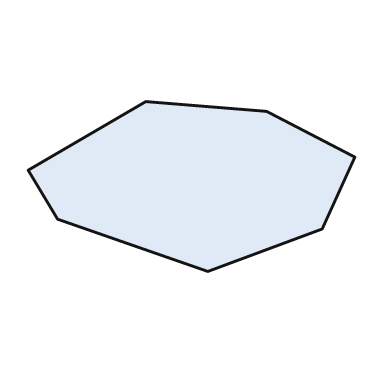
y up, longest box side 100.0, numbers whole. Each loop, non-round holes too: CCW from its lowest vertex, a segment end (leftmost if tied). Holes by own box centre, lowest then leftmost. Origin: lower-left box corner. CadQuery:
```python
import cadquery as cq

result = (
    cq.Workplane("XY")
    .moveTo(55.0, 0.0)
    .lineTo(90.0, 13.0)
    .lineTo(100.0, 35.0)
    .lineTo(73.0, 49.0)
    .lineTo(36.0, 52.0)
    .lineTo(0.0, 31.0)
    .lineTo(9.0, 16.0)
    .close()
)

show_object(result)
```